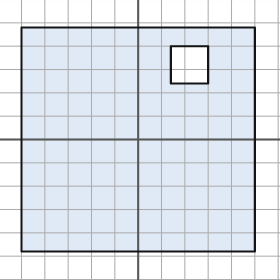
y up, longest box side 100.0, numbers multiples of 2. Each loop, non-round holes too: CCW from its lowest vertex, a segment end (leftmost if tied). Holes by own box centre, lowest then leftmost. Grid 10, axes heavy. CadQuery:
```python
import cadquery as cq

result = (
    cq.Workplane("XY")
    .moveTo(-50.0, -48.0)
    .lineTo(50.0, -48.0)
    .lineTo(50.0, 48.0)
    .lineTo(-50.0, 48.0)
    .close()
    .moveTo(14.0, 24.0)
    .lineTo(30.0, 24.0)
    .lineTo(30.0, 40.0)
    .lineTo(14.0, 40.0)
    .close()
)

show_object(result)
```